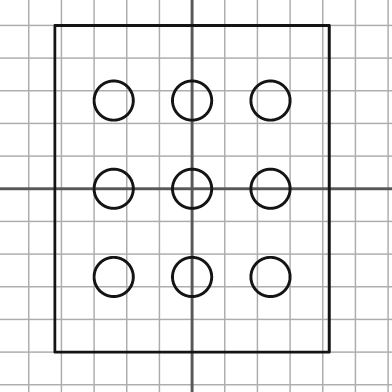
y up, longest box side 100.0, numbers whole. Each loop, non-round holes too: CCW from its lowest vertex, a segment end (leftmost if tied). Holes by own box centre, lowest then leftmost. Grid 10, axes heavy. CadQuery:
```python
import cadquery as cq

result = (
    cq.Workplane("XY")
    .moveTo(-42.0, -50.0)
    .lineTo(42.0, -50.0)
    .lineTo(42.0, 50.0)
    .lineTo(-42.0, 50.0)
    .close()
    .moveTo(-24.0, -27.0)
    .circle(6.0)
    .moveTo(0.0, -27.0)
    .circle(6.0)
    .moveTo(24.0, -27.0)
    .circle(6.0)
    .moveTo(-24.0, 0.0)
    .circle(6.0)
    .moveTo(0.0, 0.0)
    .circle(6.0)
    .moveTo(24.0, 0.0)
    .circle(6.0)
    .moveTo(-24.0, 27.0)
    .circle(6.0)
    .moveTo(0.0, 27.0)
    .circle(6.0)
    .moveTo(24.0, 27.0)
    .circle(6.0)
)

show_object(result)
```